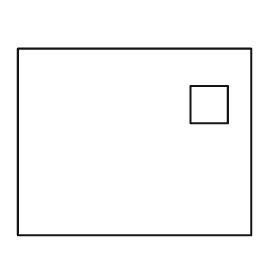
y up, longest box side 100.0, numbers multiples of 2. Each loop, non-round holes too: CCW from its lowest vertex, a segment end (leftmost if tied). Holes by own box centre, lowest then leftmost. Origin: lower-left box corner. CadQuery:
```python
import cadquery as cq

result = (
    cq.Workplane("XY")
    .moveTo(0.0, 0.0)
    .lineTo(100.0, 0.0)
    .lineTo(100.0, 80.0)
    .lineTo(0.0, 80.0)
    .close()
    .moveTo(74.0, 48.0)
    .lineTo(90.0, 48.0)
    .lineTo(90.0, 64.0)
    .lineTo(74.0, 64.0)
    .close()
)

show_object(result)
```